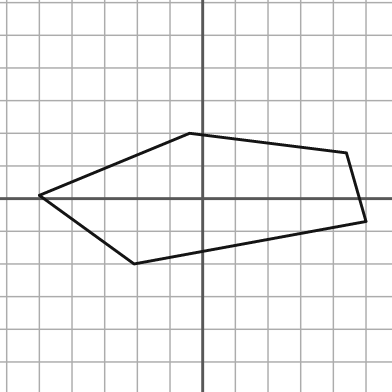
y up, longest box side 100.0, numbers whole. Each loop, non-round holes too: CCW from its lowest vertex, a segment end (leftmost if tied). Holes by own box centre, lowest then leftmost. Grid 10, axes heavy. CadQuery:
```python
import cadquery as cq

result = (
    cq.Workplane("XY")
    .moveTo(-21.0, -20.0)
    .lineTo(50.0, -7.0)
    .lineTo(44.0, 14.0)
    .lineTo(-4.0, 20.0)
    .lineTo(-50.0, 1.0)
    .close()
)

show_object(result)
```